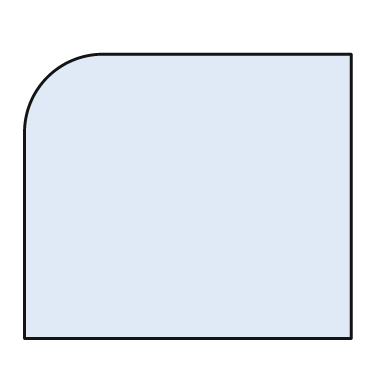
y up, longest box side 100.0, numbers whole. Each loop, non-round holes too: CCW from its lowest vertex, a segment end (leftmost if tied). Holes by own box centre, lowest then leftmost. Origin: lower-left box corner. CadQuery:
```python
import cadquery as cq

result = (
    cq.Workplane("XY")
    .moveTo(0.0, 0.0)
    .lineTo(100.0, 0.0)
    .lineTo(100.0, 87.0)
    .lineTo(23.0, 87.0)
    .threePointArc((7.0, 80.0), (0.0, 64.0))
    .close()
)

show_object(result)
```